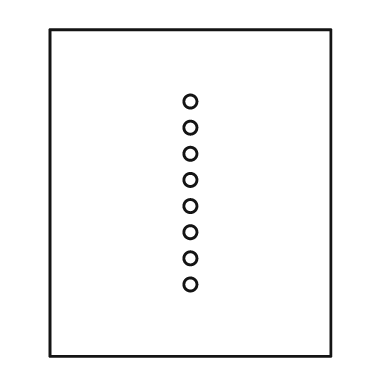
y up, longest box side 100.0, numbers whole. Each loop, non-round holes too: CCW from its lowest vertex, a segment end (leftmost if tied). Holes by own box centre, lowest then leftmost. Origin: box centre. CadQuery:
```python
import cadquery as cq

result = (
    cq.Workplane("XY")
    .moveTo(-43.0, -50.0)
    .lineTo(43.0, -50.0)
    .lineTo(43.0, 50.0)
    .lineTo(-43.0, 50.0)
    .close()
    .moveTo(0.0, -28.0)
    .circle(2.0)
    .moveTo(0.0, -20.0)
    .circle(2.0)
    .moveTo(0.0, -12.0)
    .circle(2.0)
    .moveTo(0.0, -4.0)
    .circle(2.0)
    .moveTo(0.0, 4.0)
    .circle(2.0)
    .moveTo(0.0, 12.0)
    .circle(2.0)
    .moveTo(0.0, 20.0)
    .circle(2.0)
    .moveTo(0.0, 28.0)
    .circle(2.0)
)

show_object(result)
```